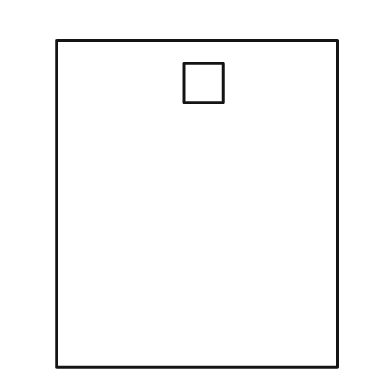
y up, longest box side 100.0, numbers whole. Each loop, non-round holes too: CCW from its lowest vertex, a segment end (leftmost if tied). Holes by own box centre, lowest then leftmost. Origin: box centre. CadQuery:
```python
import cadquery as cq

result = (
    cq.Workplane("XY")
    .moveTo(-43.0, -50.0)
    .lineTo(43.0, -50.0)
    .lineTo(43.0, 50.0)
    .lineTo(-43.0, 50.0)
    .close()
    .moveTo(-4.0, 31.0)
    .lineTo(8.0, 31.0)
    .lineTo(8.0, 43.0)
    .lineTo(-4.0, 43.0)
    .close()
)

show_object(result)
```